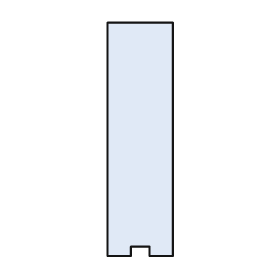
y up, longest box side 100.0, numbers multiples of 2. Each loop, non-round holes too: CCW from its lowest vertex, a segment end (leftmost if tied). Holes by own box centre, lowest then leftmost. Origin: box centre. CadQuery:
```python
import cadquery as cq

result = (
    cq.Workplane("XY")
    .moveTo(-14.0, -50.0)
    .lineTo(-4.0, -50.0)
    .lineTo(-4.0, -46.0)
    .lineTo(4.0, -46.0)
    .lineTo(4.0, -50.0)
    .lineTo(14.0, -50.0)
    .lineTo(14.0, 50.0)
    .lineTo(-14.0, 50.0)
    .close()
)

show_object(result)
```